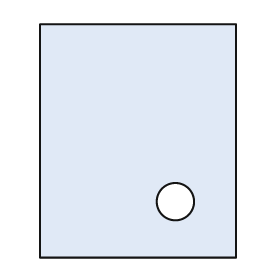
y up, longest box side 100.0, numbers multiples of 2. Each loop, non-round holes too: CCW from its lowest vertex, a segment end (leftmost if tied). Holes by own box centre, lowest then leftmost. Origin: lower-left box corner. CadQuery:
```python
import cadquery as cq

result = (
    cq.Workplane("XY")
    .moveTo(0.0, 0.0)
    .lineTo(84.0, 0.0)
    .lineTo(84.0, 100.0)
    .lineTo(0.0, 100.0)
    .close()
    .moveTo(58.0, 24.0)
    .circle(8.0)
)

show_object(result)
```